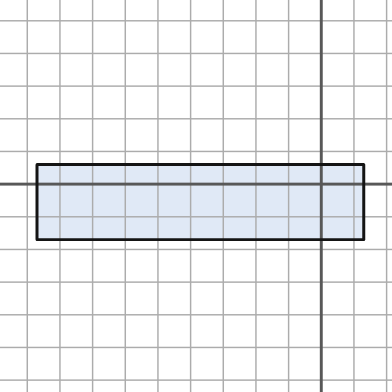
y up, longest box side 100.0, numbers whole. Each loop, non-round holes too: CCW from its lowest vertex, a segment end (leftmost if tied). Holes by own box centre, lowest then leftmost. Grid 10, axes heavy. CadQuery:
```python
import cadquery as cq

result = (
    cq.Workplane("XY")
    .moveTo(-87.0, -17.0)
    .lineTo(13.0, -17.0)
    .lineTo(13.0, 6.0)
    .lineTo(-87.0, 6.0)
    .close()
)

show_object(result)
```